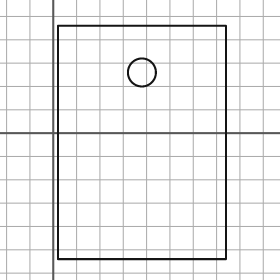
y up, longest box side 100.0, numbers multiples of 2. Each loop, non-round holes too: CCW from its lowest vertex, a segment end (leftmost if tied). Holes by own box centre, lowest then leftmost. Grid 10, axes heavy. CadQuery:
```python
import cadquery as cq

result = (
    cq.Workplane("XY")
    .moveTo(2.0, -54.0)
    .lineTo(74.0, -54.0)
    .lineTo(74.0, 46.0)
    .lineTo(2.0, 46.0)
    .close()
    .moveTo(38.0, 26.0)
    .circle(6.0)
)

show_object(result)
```